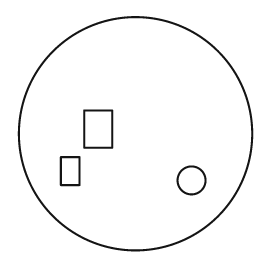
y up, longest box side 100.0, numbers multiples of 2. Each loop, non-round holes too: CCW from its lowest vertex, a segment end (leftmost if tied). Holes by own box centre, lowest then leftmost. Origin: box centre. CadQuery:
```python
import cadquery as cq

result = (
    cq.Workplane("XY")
    .moveTo(0.0, 0.0)
    .circle(50.0)
    .moveTo(24.0, -20.0)
    .circle(6.0)
    .moveTo(-32.0, -22.0)
    .lineTo(-24.0, -22.0)
    .lineTo(-24.0, -10.0)
    .lineTo(-32.0, -10.0)
    .close()
    .moveTo(-22.0, -6.0)
    .lineTo(-10.0, -6.0)
    .lineTo(-10.0, 10.0)
    .lineTo(-22.0, 10.0)
    .close()
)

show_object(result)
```